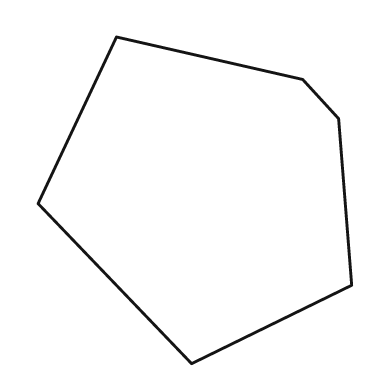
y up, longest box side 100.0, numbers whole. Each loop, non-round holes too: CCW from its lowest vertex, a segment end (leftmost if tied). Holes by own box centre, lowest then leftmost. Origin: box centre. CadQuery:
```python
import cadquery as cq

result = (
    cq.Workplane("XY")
    .moveTo(-1.0, -50.0)
    .lineTo(48.0, -26.0)
    .lineTo(44.0, 25.0)
    .lineTo(33.0, 37.0)
    .lineTo(-24.0, 50.0)
    .lineTo(-48.0, -1.0)
    .close()
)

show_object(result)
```